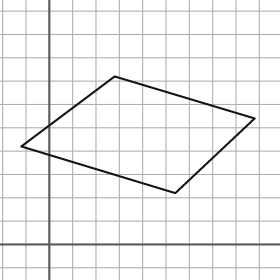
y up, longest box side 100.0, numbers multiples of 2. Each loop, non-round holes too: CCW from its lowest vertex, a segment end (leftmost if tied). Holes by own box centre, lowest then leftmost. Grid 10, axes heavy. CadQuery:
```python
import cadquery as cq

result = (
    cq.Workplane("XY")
    .moveTo(54.0, 22.0)
    .lineTo(88.0, 54.0)
    .lineTo(28.0, 72.0)
    .lineTo(-12.0, 42.0)
    .close()
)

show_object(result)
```